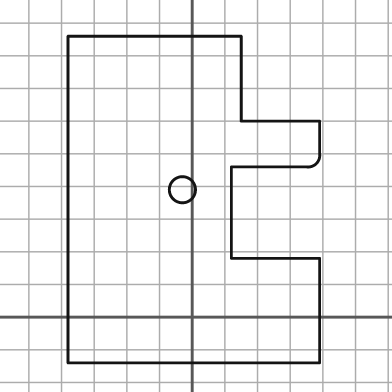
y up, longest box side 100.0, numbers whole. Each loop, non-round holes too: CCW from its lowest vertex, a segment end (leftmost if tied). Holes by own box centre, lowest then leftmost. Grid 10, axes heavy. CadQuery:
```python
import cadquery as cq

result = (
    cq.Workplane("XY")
    .moveTo(-38.0, -14.0)
    .lineTo(39.0, -14.0)
    .lineTo(39.0, 18.0)
    .lineTo(12.0, 18.0)
    .lineTo(12.0, 46.0)
    .lineTo(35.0, 46.0)
    .threePointArc((38.0, 47.0), (39.0, 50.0))
    .lineTo(39.0, 60.0)
    .lineTo(15.0, 60.0)
    .lineTo(15.0, 86.0)
    .lineTo(-38.0, 86.0)
    .close()
    .moveTo(-3.0, 39.0)
    .circle(4.0)
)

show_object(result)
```